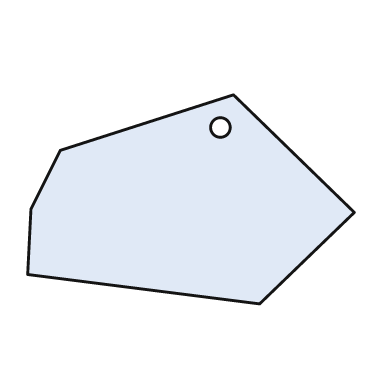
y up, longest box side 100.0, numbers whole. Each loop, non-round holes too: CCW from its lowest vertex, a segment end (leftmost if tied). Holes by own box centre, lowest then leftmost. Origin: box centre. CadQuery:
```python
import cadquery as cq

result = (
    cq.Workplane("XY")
    .moveTo(21.0, -32.0)
    .lineTo(50.0, -4.0)
    .lineTo(13.0, 32.0)
    .lineTo(-40.0, 15.0)
    .lineTo(-49.0, -3.0)
    .lineTo(-50.0, -23.0)
    .close()
    .moveTo(9.0, 22.0)
    .circle(3.0)
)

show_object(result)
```